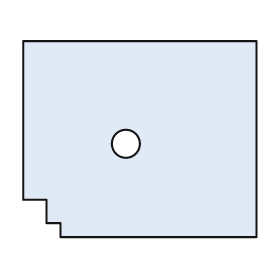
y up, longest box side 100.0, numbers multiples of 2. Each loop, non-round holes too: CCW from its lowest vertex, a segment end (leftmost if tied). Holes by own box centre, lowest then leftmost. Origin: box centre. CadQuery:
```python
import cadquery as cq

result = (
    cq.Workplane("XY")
    .moveTo(-34.0, -42.0)
    .lineTo(50.0, -42.0)
    .lineTo(50.0, 42.0)
    .lineTo(-50.0, 42.0)
    .lineTo(-50.0, -26.0)
    .lineTo(-40.0, -26.0)
    .lineTo(-40.0, -36.0)
    .lineTo(-34.0, -36.0)
    .close()
    .moveTo(-6.0, -2.0)
    .circle(6.0)
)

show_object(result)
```